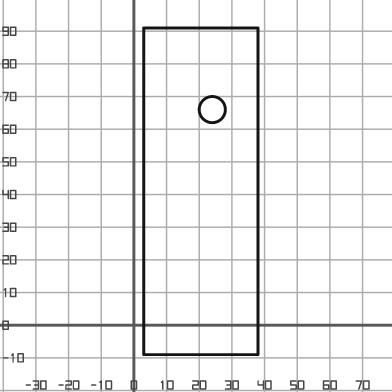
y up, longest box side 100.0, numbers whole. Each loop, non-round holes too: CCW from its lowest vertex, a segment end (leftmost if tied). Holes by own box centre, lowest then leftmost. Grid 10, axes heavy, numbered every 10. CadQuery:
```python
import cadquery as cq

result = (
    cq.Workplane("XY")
    .moveTo(3.0, -9.0)
    .lineTo(38.0, -9.0)
    .lineTo(38.0, 91.0)
    .lineTo(3.0, 91.0)
    .close()
    .moveTo(24.0, 66.0)
    .circle(4.0)
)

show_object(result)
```